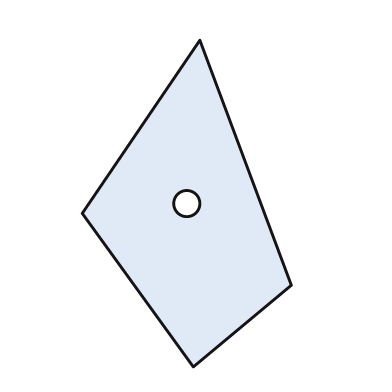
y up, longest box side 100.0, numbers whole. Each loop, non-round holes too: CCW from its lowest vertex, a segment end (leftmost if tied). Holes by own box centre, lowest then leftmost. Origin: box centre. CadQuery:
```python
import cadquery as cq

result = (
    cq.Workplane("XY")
    .moveTo(2.0, -50.0)
    .lineTo(32.0, -25.0)
    .lineTo(4.0, 50.0)
    .lineTo(-32.0, -3.0)
    .close()
    .moveTo(0.0, 0.0)
    .circle(4.0)
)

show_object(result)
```